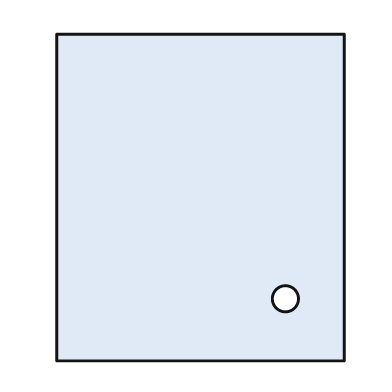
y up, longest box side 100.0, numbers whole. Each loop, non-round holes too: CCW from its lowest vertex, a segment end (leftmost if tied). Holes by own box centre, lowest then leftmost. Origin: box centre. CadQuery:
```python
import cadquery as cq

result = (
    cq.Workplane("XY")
    .moveTo(-44.0, -50.0)
    .lineTo(44.0, -50.0)
    .lineTo(44.0, 50.0)
    .lineTo(-44.0, 50.0)
    .close()
    .moveTo(26.0, -31.0)
    .circle(4.0)
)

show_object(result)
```